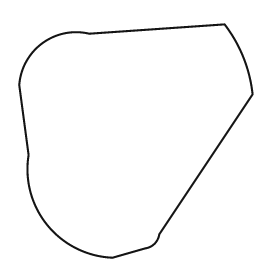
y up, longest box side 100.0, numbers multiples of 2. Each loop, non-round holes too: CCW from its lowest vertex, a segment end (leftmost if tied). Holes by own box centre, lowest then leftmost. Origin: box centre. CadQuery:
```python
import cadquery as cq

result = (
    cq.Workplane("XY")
    .moveTo(-10.0, -50.0)
    .lineTo(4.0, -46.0)
    .threePointArc((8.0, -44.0), (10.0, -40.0))
    .lineTo(50.0, 20.0)
    .threePointArc((46.0, 36.0), (38.0, 50.0))
    .lineTo(-20.0, 46.0)
    .threePointArc((-40.0, 42.0), (-50.0, 24.0))
    .lineTo(-46.0, -6.0)
    .threePointArc((-38.0, -36.0), (-10.0, -50.0))
    .close()
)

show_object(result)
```